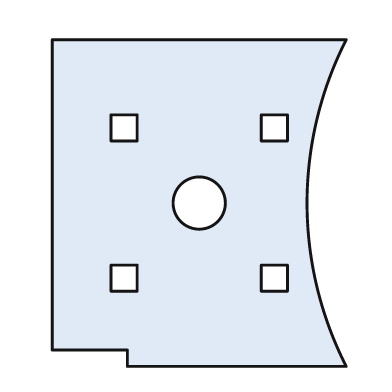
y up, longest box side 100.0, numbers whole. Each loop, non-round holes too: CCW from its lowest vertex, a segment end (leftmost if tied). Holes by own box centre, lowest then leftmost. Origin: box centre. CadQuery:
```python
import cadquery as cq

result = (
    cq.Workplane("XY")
    .moveTo(-22.0, -50.0)
    .lineTo(45.0, -50.0)
    .threePointArc((33.0, 0.0), (45.0, 50.0))
    .lineTo(-45.0, 50.0)
    .lineTo(-45.0, -45.0)
    .lineTo(-22.0, -45.0)
    .close()
    .moveTo(-27.0, -27.0)
    .lineTo(-19.0, -27.0)
    .lineTo(-19.0, -19.0)
    .lineTo(-27.0, -19.0)
    .close()
    .moveTo(19.0, -27.0)
    .lineTo(27.0, -27.0)
    .lineTo(27.0, -19.0)
    .lineTo(19.0, -19.0)
    .close()
    .moveTo(0.0, 0.0)
    .circle(8.0)
    .moveTo(-27.0, 19.0)
    .lineTo(-19.0, 19.0)
    .lineTo(-19.0, 27.0)
    .lineTo(-27.0, 27.0)
    .close()
    .moveTo(19.0, 19.0)
    .lineTo(27.0, 19.0)
    .lineTo(27.0, 27.0)
    .lineTo(19.0, 27.0)
    .close()
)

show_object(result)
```